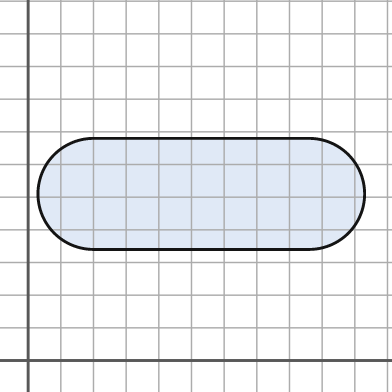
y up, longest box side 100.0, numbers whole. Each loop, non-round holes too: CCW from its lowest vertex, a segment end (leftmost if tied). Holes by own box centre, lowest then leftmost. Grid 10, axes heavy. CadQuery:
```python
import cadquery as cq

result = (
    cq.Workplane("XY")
    .moveTo(20.0, 34.0)
    .lineTo(86.0, 34.0)
    .threePointArc((103.0, 51.0), (86.0, 68.0))
    .lineTo(20.0, 68.0)
    .threePointArc((3.0, 51.0), (20.0, 34.0))
    .close()
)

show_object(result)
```